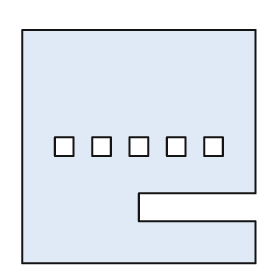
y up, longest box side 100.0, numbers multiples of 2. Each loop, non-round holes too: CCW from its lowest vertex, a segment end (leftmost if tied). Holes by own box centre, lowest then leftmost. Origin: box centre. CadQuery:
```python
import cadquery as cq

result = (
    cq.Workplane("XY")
    .moveTo(-50.0, -50.0)
    .lineTo(50.0, -50.0)
    .lineTo(50.0, -32.0)
    .lineTo(0.0, -32.0)
    .lineTo(0.0, -20.0)
    .lineTo(50.0, -20.0)
    .lineTo(50.0, 50.0)
    .lineTo(-50.0, 50.0)
    .close()
    .moveTo(-36.0, -4.0)
    .lineTo(-28.0, -4.0)
    .lineTo(-28.0, 4.0)
    .lineTo(-36.0, 4.0)
    .close()
    .moveTo(-20.0, -4.0)
    .lineTo(-12.0, -4.0)
    .lineTo(-12.0, 4.0)
    .lineTo(-20.0, 4.0)
    .close()
    .moveTo(-4.0, -4.0)
    .lineTo(4.0, -4.0)
    .lineTo(4.0, 4.0)
    .lineTo(-4.0, 4.0)
    .close()
    .moveTo(12.0, -4.0)
    .lineTo(20.0, -4.0)
    .lineTo(20.0, 4.0)
    .lineTo(12.0, 4.0)
    .close()
    .moveTo(28.0, -4.0)
    .lineTo(36.0, -4.0)
    .lineTo(36.0, 4.0)
    .lineTo(28.0, 4.0)
    .close()
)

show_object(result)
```